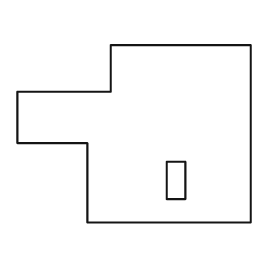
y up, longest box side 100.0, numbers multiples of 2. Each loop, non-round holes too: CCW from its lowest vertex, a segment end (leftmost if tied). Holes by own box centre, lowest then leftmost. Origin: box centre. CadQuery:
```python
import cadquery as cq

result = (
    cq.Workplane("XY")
    .moveTo(-20.0, -38.0)
    .lineTo(50.0, -38.0)
    .lineTo(50.0, 38.0)
    .lineTo(-10.0, 38.0)
    .lineTo(-10.0, 18.0)
    .lineTo(-50.0, 18.0)
    .lineTo(-50.0, -4.0)
    .lineTo(-20.0, -4.0)
    .close()
    .moveTo(14.0, -28.0)
    .lineTo(22.0, -28.0)
    .lineTo(22.0, -12.0)
    .lineTo(14.0, -12.0)
    .close()
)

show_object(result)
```